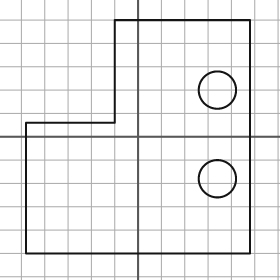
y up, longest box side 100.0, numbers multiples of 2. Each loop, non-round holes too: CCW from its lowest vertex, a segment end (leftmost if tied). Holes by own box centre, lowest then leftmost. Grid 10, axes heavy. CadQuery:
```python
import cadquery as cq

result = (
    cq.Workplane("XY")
    .moveTo(-48.0, -50.0)
    .lineTo(48.0, -50.0)
    .lineTo(48.0, 50.0)
    .lineTo(-10.0, 50.0)
    .lineTo(-10.0, 6.0)
    .lineTo(-48.0, 6.0)
    .close()
    .moveTo(34.0, -18.0)
    .circle(8.0)
    .moveTo(34.0, 20.0)
    .circle(8.0)
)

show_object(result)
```